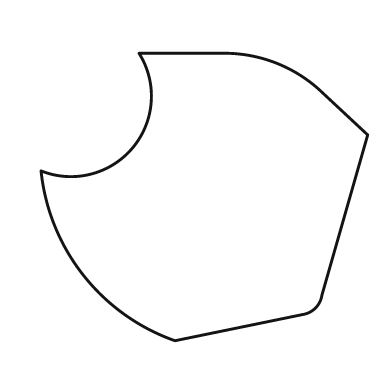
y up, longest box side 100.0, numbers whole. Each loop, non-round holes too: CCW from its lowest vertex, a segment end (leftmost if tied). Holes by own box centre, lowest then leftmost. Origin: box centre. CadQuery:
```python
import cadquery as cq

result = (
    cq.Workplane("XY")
    .moveTo(-9.0, -44.0)
    .lineTo(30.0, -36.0)
    .threePointArc((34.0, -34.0), (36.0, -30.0))
    .lineTo(50.0, 19.0)
    .lineTo(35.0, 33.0)
    .threePointArc((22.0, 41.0), (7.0, 44.0))
    .lineTo(-20.0, 44.0)
    .threePointArc((-22.0, 15.0), (-50.0, 8.0))
    .threePointArc((-37.0, -24.0), (-9.0, -44.0))
    .close()
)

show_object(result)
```